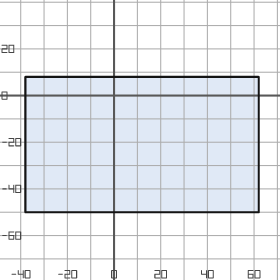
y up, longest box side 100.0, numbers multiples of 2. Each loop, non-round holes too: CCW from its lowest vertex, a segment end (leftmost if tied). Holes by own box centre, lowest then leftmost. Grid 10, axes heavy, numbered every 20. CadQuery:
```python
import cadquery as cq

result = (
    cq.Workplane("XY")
    .moveTo(-38.0, -50.0)
    .lineTo(62.0, -50.0)
    .lineTo(62.0, 8.0)
    .lineTo(-38.0, 8.0)
    .close()
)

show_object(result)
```